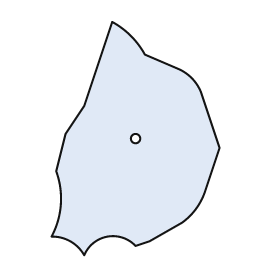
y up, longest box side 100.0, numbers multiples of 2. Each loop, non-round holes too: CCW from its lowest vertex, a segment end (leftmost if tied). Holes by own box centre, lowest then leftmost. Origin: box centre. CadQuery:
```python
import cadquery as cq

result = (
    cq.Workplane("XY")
    .moveTo(-22.0, -50.0)
    .threePointArc((-12.0, -42.0), (0.0, -46.0))
    .lineTo(6.0, -44.0)
    .lineTo(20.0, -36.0)
    .threePointArc((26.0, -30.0), (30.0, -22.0))
    .lineTo(36.0, -4.0)
    .lineTo(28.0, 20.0)
    .threePointArc((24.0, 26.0), (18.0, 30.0))
    .lineTo(4.0, 36.0)
    .threePointArc((-2.0, 44.0), (-10.0, 50.0))
    .lineTo(-22.0, 14.0)
    .lineTo(-30.0, 2.0)
    .lineTo(-34.0, -14.0)
    .threePointArc((-32.0, -28.0), (-36.0, -42.0))
    .threePointArc((-28.0, -44.0), (-22.0, -50.0))
    .close()
    .moveTo(0.0, 0.0)
    .circle(2.0)
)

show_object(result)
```